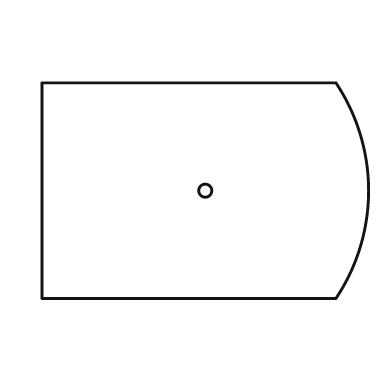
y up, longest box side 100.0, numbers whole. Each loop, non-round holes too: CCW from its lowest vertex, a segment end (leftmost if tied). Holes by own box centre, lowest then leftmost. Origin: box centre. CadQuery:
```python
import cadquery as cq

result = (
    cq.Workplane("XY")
    .moveTo(-50.0, -33.0)
    .lineTo(40.0, -33.0)
    .threePointArc((50.0, 0.0), (40.0, 33.0))
    .lineTo(-50.0, 33.0)
    .close()
    .moveTo(0.0, 0.0)
    .circle(2.0)
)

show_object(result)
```